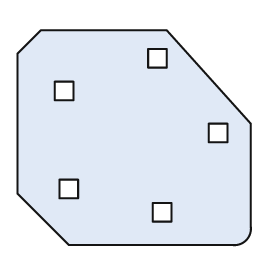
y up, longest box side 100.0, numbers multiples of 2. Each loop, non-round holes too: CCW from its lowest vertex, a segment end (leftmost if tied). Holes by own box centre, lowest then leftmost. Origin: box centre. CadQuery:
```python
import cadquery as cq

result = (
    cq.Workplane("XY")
    .moveTo(-28.0, -46.0)
    .lineTo(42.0, -46.0)
    .threePointArc((48.0, -44.0), (50.0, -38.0))
    .lineTo(50.0, 6.0)
    .lineTo(14.0, 46.0)
    .lineTo(-40.0, 46.0)
    .lineTo(-50.0, 36.0)
    .lineTo(-50.0, -24.0)
    .close()
    .moveTo(8.0, -36.0)
    .lineTo(16.0, -36.0)
    .lineTo(16.0, -28.0)
    .lineTo(8.0, -28.0)
    .close()
    .moveTo(-32.0, -26.0)
    .lineTo(-24.0, -26.0)
    .lineTo(-24.0, -18.0)
    .lineTo(-32.0, -18.0)
    .close()
    .moveTo(32.0, -2.0)
    .lineTo(40.0, -2.0)
    .lineTo(40.0, 6.0)
    .lineTo(32.0, 6.0)
    .close()
    .moveTo(-34.0, 16.0)
    .lineTo(-26.0, 16.0)
    .lineTo(-26.0, 24.0)
    .lineTo(-34.0, 24.0)
    .close()
    .moveTo(6.0, 30.0)
    .lineTo(14.0, 30.0)
    .lineTo(14.0, 38.0)
    .lineTo(6.0, 38.0)
    .close()
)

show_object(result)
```